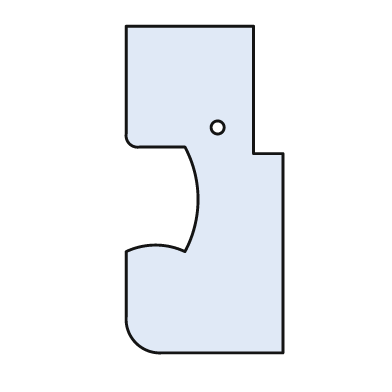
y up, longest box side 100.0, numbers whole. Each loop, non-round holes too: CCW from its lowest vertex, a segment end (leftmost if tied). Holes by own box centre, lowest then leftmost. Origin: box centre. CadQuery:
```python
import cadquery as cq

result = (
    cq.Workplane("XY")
    .moveTo(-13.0, -50.0)
    .lineTo(24.0, -50.0)
    .lineTo(24.0, 11.0)
    .lineTo(15.0, 11.0)
    .lineTo(15.0, 50.0)
    .lineTo(-24.0, 50.0)
    .lineTo(-24.0, 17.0)
    .threePointArc((-23.0, 14.0), (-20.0, 13.0))
    .lineTo(-6.0, 13.0)
    .threePointArc((-2.0, -3.0), (-6.0, -19.0))
    .threePointArc((-15.0, -17.0), (-24.0, -19.0))
    .lineTo(-24.0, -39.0)
    .threePointArc((-21.0, -47.0), (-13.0, -50.0))
    .close()
    .moveTo(4.0, 19.0)
    .circle(2.0)
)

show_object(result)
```